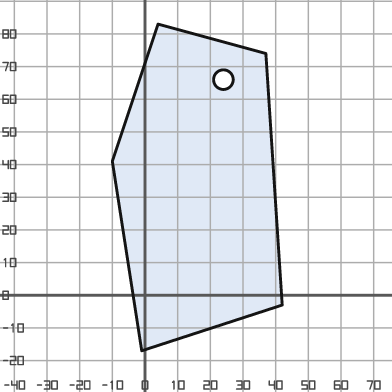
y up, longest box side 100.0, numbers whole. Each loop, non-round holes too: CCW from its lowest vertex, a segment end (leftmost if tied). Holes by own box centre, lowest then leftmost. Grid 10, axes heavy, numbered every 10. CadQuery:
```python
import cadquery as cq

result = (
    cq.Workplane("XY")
    .moveTo(-1.0, -17.0)
    .lineTo(42.0, -3.0)
    .lineTo(37.0, 74.0)
    .lineTo(4.0, 83.0)
    .lineTo(-10.0, 41.0)
    .close()
    .moveTo(24.0, 66.0)
    .circle(3.0)
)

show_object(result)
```